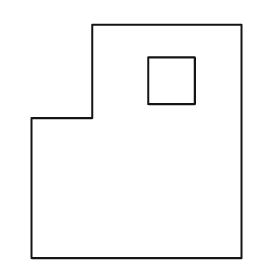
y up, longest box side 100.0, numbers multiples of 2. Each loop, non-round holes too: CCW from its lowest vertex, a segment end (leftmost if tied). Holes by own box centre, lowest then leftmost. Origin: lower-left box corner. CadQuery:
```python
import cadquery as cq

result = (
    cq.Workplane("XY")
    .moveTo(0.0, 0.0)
    .lineTo(90.0, 0.0)
    .lineTo(90.0, 100.0)
    .lineTo(26.0, 100.0)
    .lineTo(26.0, 60.0)
    .lineTo(0.0, 60.0)
    .close()
    .moveTo(50.0, 66.0)
    .lineTo(70.0, 66.0)
    .lineTo(70.0, 86.0)
    .lineTo(50.0, 86.0)
    .close()
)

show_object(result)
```